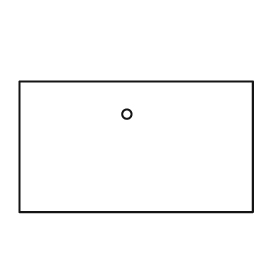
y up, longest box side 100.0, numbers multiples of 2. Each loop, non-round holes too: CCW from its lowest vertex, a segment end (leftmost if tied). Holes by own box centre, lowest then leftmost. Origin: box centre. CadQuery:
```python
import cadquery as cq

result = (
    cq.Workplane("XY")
    .moveTo(-50.0, -28.0)
    .lineTo(50.0, -28.0)
    .lineTo(50.0, 28.0)
    .lineTo(-50.0, 28.0)
    .close()
    .moveTo(-4.0, 14.0)
    .circle(2.0)
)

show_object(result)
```